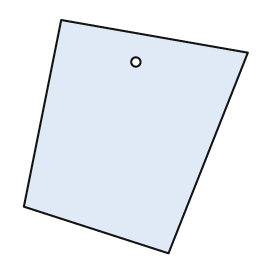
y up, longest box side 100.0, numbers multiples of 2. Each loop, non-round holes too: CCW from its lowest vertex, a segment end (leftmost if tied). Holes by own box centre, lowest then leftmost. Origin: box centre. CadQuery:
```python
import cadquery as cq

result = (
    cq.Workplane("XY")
    .moveTo(14.0, -50.0)
    .lineTo(48.0, 36.0)
    .lineTo(-32.0, 50.0)
    .lineTo(-48.0, -30.0)
    .close()
    .moveTo(0.0, 32.0)
    .circle(2.0)
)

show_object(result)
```